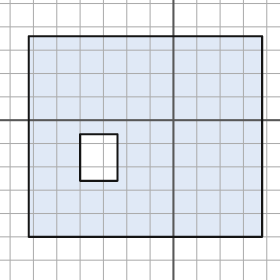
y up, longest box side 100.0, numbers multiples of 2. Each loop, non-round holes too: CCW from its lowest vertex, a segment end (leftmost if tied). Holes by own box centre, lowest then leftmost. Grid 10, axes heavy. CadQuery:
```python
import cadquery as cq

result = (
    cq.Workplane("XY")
    .moveTo(-62.0, -50.0)
    .lineTo(38.0, -50.0)
    .lineTo(38.0, 36.0)
    .lineTo(-62.0, 36.0)
    .close()
    .moveTo(-40.0, -26.0)
    .lineTo(-24.0, -26.0)
    .lineTo(-24.0, -6.0)
    .lineTo(-40.0, -6.0)
    .close()
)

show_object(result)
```